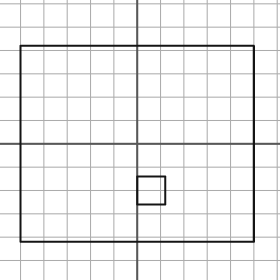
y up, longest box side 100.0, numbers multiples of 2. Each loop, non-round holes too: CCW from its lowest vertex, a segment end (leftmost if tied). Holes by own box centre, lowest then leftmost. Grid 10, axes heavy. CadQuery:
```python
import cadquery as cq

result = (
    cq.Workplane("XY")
    .moveTo(-50.0, -42.0)
    .lineTo(50.0, -42.0)
    .lineTo(50.0, 42.0)
    .lineTo(-50.0, 42.0)
    .close()
    .moveTo(0.0, -26.0)
    .lineTo(12.0, -26.0)
    .lineTo(12.0, -14.0)
    .lineTo(0.0, -14.0)
    .close()
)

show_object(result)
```